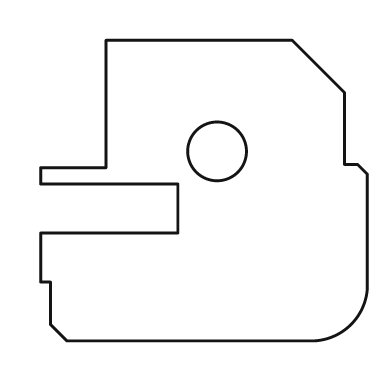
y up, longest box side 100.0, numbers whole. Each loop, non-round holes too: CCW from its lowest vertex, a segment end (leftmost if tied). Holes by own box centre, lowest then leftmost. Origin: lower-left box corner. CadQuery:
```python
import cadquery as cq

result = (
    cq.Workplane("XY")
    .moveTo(8.0, 0.0)
    .lineTo(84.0, 0.0)
    .threePointArc((95.0, 5.0), (100.0, 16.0))
    .lineTo(100.0, 51.0)
    .lineTo(97.0, 54.0)
    .lineTo(93.0, 54.0)
    .lineTo(93.0, 76.0)
    .lineTo(77.0, 92.0)
    .lineTo(20.0, 92.0)
    .lineTo(20.0, 53.0)
    .lineTo(0.0, 53.0)
    .lineTo(0.0, 48.0)
    .lineTo(42.0, 48.0)
    .lineTo(42.0, 33.0)
    .lineTo(0.0, 33.0)
    .lineTo(0.0, 18.0)
    .lineTo(3.0, 18.0)
    .lineTo(3.0, 5.0)
    .close()
    .moveTo(54.0, 58.0)
    .circle(9.0)
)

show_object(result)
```